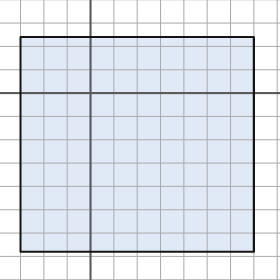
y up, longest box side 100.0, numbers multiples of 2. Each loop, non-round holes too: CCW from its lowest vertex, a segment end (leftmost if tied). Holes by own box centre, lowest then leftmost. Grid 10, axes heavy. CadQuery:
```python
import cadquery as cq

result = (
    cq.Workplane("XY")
    .moveTo(-30.0, -68.0)
    .lineTo(70.0, -68.0)
    .lineTo(70.0, 24.0)
    .lineTo(-30.0, 24.0)
    .close()
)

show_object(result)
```